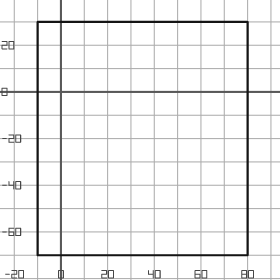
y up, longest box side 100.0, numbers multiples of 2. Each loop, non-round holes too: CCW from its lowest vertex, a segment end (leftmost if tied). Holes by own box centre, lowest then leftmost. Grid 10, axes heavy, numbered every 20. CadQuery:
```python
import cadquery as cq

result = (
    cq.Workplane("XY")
    .moveTo(-10.0, -70.0)
    .lineTo(80.0, -70.0)
    .lineTo(80.0, 30.0)
    .lineTo(-10.0, 30.0)
    .close()
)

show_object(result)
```